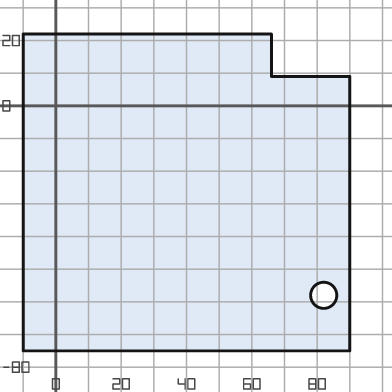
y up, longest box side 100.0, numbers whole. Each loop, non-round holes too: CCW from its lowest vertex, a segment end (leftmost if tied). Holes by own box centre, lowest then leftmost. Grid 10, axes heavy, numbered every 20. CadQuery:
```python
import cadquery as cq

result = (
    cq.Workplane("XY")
    .moveTo(-10.0, -75.0)
    .lineTo(90.0, -75.0)
    .lineTo(90.0, 9.0)
    .lineTo(66.0, 9.0)
    .lineTo(66.0, 22.0)
    .lineTo(-10.0, 22.0)
    .close()
    .moveTo(82.0, -58.0)
    .circle(4.0)
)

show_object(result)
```